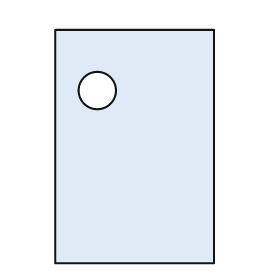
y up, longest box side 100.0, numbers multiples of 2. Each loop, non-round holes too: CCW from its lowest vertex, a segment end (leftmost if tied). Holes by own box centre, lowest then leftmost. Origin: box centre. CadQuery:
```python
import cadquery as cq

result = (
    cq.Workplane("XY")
    .moveTo(-34.0, -50.0)
    .lineTo(34.0, -50.0)
    .lineTo(34.0, 50.0)
    .lineTo(-34.0, 50.0)
    .close()
    .moveTo(-16.0, 24.0)
    .circle(8.0)
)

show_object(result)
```